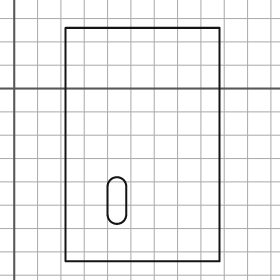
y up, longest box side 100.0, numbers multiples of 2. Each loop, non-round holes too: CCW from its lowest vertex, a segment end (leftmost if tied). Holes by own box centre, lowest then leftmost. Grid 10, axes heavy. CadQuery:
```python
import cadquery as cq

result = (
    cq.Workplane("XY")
    .moveTo(22.0, -74.0)
    .lineTo(88.0, -74.0)
    .lineTo(88.0, 26.0)
    .lineTo(22.0, 26.0)
    .close()
    .moveTo(40.0, -54.0)
    .threePointArc((44.0, -58.0), (48.0, -54.0))
    .lineTo(48.0, -42.0)
    .threePointArc((44.0, -38.0), (40.0, -42.0))
    .close()
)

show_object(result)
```